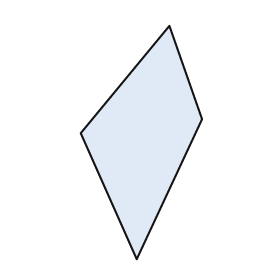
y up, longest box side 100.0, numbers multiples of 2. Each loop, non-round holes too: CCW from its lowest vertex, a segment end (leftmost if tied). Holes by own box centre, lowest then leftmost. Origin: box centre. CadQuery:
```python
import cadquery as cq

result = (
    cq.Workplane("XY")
    .moveTo(-2.0, -50.0)
    .lineTo(26.0, 10.0)
    .lineTo(12.0, 50.0)
    .lineTo(-26.0, 4.0)
    .close()
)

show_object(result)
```